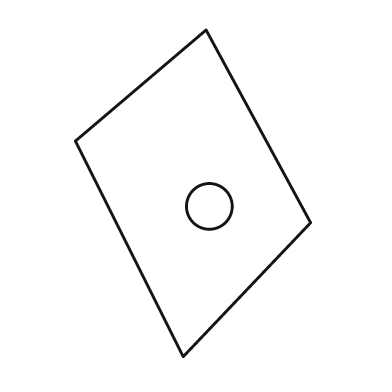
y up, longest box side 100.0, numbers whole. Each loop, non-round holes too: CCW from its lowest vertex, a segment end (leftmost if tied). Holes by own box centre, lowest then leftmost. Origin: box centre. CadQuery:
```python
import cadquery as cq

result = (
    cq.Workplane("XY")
    .moveTo(-3.0, -50.0)
    .lineTo(36.0, -9.0)
    .lineTo(4.0, 50.0)
    .lineTo(-36.0, 16.0)
    .close()
    .moveTo(5.0, -4.0)
    .circle(7.0)
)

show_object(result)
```